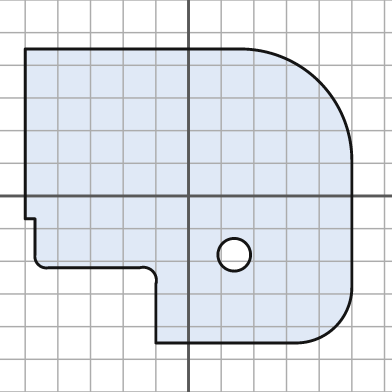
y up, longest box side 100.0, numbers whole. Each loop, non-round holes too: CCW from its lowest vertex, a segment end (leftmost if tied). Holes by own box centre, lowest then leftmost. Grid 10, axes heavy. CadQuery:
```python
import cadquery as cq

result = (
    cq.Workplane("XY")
    .moveTo(-10.0, -45.0)
    .lineTo(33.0, -45.0)
    .threePointArc((45.0, -40.0), (50.0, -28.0))
    .lineTo(50.0, 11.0)
    .threePointArc((40.0, 35.0), (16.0, 45.0))
    .lineTo(-50.0, 45.0)
    .lineTo(-50.0, -7.0)
    .lineTo(-47.0, -7.0)
    .lineTo(-47.0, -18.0)
    .threePointArc((-46.0, -21.0), (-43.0, -22.0))
    .lineTo(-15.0, -22.0)
    .threePointArc((-11.0, -23.0), (-10.0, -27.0))
    .close()
    .moveTo(14.0, -18.0)
    .circle(5.0)
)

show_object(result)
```